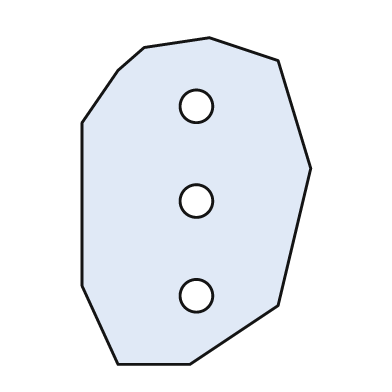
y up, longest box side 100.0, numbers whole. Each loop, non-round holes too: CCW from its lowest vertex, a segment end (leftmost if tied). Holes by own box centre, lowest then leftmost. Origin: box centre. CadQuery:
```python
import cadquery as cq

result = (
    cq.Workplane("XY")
    .moveTo(-24.0, -50.0)
    .lineTo(-2.0, -50.0)
    .lineTo(25.0, -32.0)
    .lineTo(35.0, 10.0)
    .lineTo(25.0, 43.0)
    .lineTo(4.0, 50.0)
    .lineTo(-16.0, 47.0)
    .lineTo(-24.0, 40.0)
    .lineTo(-35.0, 24.0)
    .lineTo(-35.0, -26.0)
    .close()
    .moveTo(0.0, -29.0)
    .circle(5.0)
    .moveTo(0.0, 0.0)
    .circle(5.0)
    .moveTo(0.0, 29.0)
    .circle(5.0)
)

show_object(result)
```